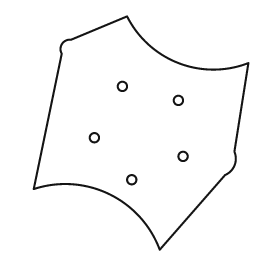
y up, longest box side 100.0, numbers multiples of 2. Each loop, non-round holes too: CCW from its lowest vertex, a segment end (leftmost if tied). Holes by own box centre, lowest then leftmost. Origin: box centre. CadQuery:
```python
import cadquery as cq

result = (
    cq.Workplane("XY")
    .moveTo(8.0, -50.0)
    .lineTo(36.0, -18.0)
    .threePointArc((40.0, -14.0), (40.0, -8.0))
    .lineTo(46.0, 30.0)
    .threePointArc((16.0, 30.0), (-6.0, 50.0))
    .lineTo(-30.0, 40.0)
    .threePointArc((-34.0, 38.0), (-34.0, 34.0))
    .lineTo(-46.0, -24.0)
    .threePointArc((-14.0, -26.0), (8.0, -50.0))
    .close()
    .moveTo(-4.0, -20.0)
    .circle(2.0)
    .moveTo(18.0, -10.0)
    .circle(2.0)
    .moveTo(-20.0, -2.0)
    .circle(2.0)
    .moveTo(16.0, 14.0)
    .circle(2.0)
    .moveTo(-8.0, 20.0)
    .circle(2.0)
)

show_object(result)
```